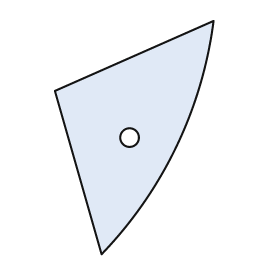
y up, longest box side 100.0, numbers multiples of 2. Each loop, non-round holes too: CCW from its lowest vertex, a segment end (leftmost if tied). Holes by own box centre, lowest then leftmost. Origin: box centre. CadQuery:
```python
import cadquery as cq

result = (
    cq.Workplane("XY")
    .moveTo(-14.0, -50.0)
    .threePointArc((18.0, -4.0), (34.0, 50.0))
    .lineTo(-34.0, 20.0)
    .close()
    .moveTo(-2.0, 0.0)
    .circle(4.0)
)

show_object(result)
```